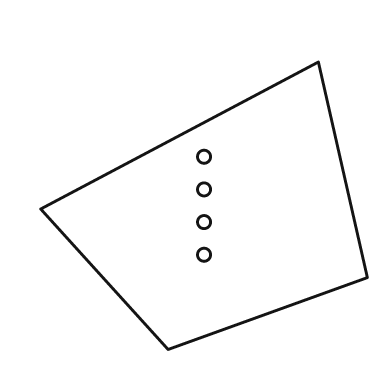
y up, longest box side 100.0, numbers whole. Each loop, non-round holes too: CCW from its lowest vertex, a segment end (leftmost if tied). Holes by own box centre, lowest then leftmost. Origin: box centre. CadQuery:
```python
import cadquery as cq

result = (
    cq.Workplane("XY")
    .moveTo(-11.0, -44.0)
    .lineTo(50.0, -22.0)
    .lineTo(35.0, 44.0)
    .lineTo(-50.0, -1.0)
    .close()
    .moveTo(0.0, -15.0)
    .circle(2.0)
    .moveTo(0.0, -5.0)
    .circle(2.0)
    .moveTo(0.0, 5.0)
    .circle(2.0)
    .moveTo(0.0, 15.0)
    .circle(2.0)
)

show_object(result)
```